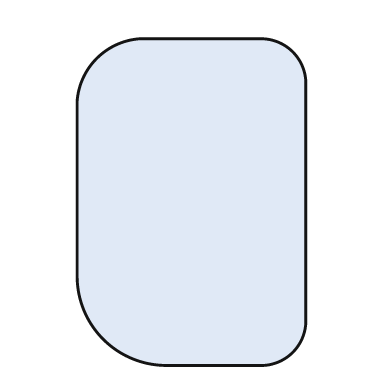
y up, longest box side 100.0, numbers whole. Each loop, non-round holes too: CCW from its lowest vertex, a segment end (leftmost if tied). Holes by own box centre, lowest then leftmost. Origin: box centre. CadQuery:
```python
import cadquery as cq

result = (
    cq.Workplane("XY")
    .moveTo(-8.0, -50.0)
    .lineTo(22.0, -50.0)
    .threePointArc((31.0, -46.0), (35.0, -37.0))
    .lineTo(35.0, 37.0)
    .threePointArc((31.0, 46.0), (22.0, 50.0))
    .lineTo(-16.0, 50.0)
    .threePointArc((-29.0, 44.0), (-35.0, 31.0))
    .lineTo(-35.0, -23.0)
    .threePointArc((-27.0, -42.0), (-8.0, -50.0))
    .close()
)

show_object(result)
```